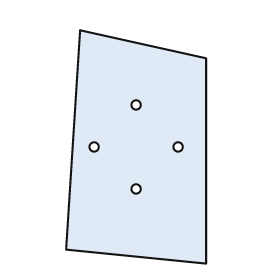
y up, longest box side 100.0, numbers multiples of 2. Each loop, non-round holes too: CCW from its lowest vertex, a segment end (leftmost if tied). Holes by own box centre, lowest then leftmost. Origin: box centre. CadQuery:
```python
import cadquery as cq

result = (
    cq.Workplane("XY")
    .moveTo(30.0, -50.0)
    .lineTo(30.0, 38.0)
    .lineTo(-24.0, 50.0)
    .lineTo(-30.0, -44.0)
    .close()
    .moveTo(0.0, -18.0)
    .circle(2.0)
    .moveTo(-18.0, 0.0)
    .circle(2.0)
    .moveTo(18.0, 0.0)
    .circle(2.0)
    .moveTo(0.0, 18.0)
    .circle(2.0)
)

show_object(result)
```